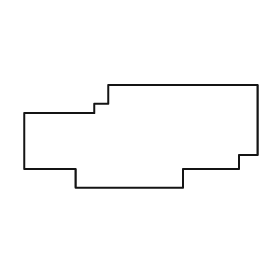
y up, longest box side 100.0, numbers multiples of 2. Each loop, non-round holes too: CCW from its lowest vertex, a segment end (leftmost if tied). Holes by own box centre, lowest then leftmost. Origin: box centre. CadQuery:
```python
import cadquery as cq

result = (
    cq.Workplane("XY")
    .moveTo(-28.0, -22.0)
    .lineTo(18.0, -22.0)
    .lineTo(18.0, -14.0)
    .lineTo(42.0, -14.0)
    .lineTo(42.0, -8.0)
    .lineTo(50.0, -8.0)
    .lineTo(50.0, 22.0)
    .lineTo(-14.0, 22.0)
    .lineTo(-14.0, 14.0)
    .lineTo(-20.0, 14.0)
    .lineTo(-20.0, 10.0)
    .lineTo(-50.0, 10.0)
    .lineTo(-50.0, -14.0)
    .lineTo(-28.0, -14.0)
    .close()
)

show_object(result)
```